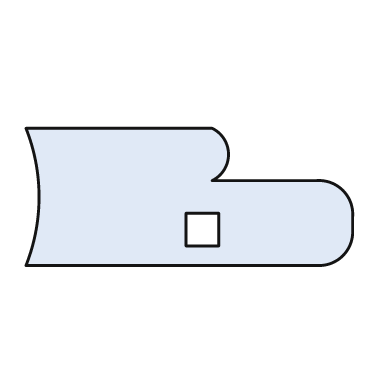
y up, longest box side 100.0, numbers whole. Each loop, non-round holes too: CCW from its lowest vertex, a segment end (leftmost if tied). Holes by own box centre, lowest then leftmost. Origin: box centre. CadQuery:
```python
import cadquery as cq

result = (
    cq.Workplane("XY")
    .moveTo(-50.0, -21.0)
    .lineTo(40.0, -21.0)
    .threePointArc((47.0, -18.0), (50.0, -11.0))
    .lineTo(50.0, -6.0)
    .threePointArc((47.0, 2.0), (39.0, 5.0))
    .lineTo(7.0, 5.0)
    .threePointArc((12.0, 13.0), (7.0, 21.0))
    .lineTo(-50.0, 21.0)
    .threePointArc((-46.0, 0.0), (-50.0, -21.0))
    .close()
    .moveTo(-1.0, -15.0)
    .lineTo(9.0, -15.0)
    .lineTo(9.0, -5.0)
    .lineTo(-1.0, -5.0)
    .close()
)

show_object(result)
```